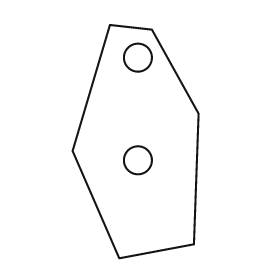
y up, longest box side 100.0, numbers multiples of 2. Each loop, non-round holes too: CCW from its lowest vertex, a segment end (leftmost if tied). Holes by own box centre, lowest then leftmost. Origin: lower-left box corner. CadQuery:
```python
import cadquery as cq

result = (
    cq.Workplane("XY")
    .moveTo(20.0, 0.0)
    .lineTo(52.0, 6.0)
    .lineTo(54.0, 62.0)
    .lineTo(34.0, 98.0)
    .lineTo(16.0, 100.0)
    .lineTo(0.0, 46.0)
    .close()
    .moveTo(28.0, 42.0)
    .circle(6.0)
    .moveTo(28.0, 86.0)
    .circle(6.0)
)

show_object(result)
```